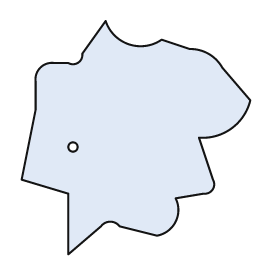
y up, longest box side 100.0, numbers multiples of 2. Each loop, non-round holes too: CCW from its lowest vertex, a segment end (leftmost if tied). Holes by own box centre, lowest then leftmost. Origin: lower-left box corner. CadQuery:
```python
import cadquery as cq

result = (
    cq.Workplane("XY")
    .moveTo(20.0, 0.0)
    .lineTo(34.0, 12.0)
    .threePointArc((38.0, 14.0), (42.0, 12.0))
    .lineTo(58.0, 8.0)
    .threePointArc((66.0, 14.0), (66.0, 24.0))
    .lineTo(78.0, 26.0)
    .threePointArc((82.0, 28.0), (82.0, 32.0))
    .lineTo(76.0, 50.0)
    .threePointArc((90.0, 54.0), (98.0, 66.0))
    .lineTo(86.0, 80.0)
    .threePointArc((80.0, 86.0), (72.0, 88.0))
    .lineTo(60.0, 92.0)
    .threePointArc((46.0, 90.0), (36.0, 100.0))
    .lineTo(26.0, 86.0)
    .threePointArc((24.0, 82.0), (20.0, 82.0))
    .lineTo(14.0, 82.0)
    .threePointArc((8.0, 80.0), (6.0, 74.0))
    .lineTo(6.0, 62.0)
    .lineTo(0.0, 32.0)
    .lineTo(20.0, 26.0)
    .close()
    .moveTo(22.0, 46.0)
    .circle(2.0)
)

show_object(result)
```